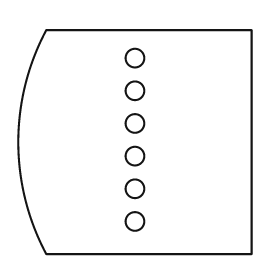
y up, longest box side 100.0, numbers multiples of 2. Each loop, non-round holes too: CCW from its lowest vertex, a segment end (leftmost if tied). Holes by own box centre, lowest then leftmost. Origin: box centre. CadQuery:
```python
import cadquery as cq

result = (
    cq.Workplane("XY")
    .moveTo(-38.0, -48.0)
    .lineTo(50.0, -48.0)
    .lineTo(50.0, 48.0)
    .lineTo(-38.0, 48.0)
    .threePointArc((-50.0, 0.0), (-38.0, -48.0))
    .close()
    .moveTo(0.0, -34.0)
    .circle(4.0)
    .moveTo(0.0, -20.0)
    .circle(4.0)
    .moveTo(0.0, -6.0)
    .circle(4.0)
    .moveTo(0.0, 8.0)
    .circle(4.0)
    .moveTo(0.0, 22.0)
    .circle(4.0)
    .moveTo(0.0, 36.0)
    .circle(4.0)
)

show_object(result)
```